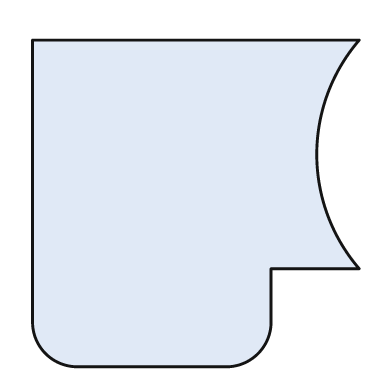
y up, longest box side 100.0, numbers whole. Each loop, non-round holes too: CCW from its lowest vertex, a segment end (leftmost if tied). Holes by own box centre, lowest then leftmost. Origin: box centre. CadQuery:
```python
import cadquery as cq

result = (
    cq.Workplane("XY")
    .moveTo(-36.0, -50.0)
    .lineTo(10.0, -50.0)
    .threePointArc((19.0, -46.0), (23.0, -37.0))
    .lineTo(23.0, -20.0)
    .lineTo(50.0, -20.0)
    .threePointArc((37.0, 15.0), (50.0, 50.0))
    .lineTo(-50.0, 50.0)
    .lineTo(-50.0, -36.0)
    .threePointArc((-46.0, -46.0), (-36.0, -50.0))
    .close()
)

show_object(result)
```